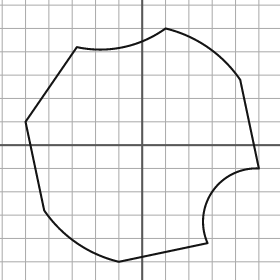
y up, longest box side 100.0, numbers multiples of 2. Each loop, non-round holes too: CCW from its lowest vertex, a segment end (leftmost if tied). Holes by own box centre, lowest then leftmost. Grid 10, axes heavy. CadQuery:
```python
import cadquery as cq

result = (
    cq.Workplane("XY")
    .moveTo(-10.0, -50.0)
    .lineTo(28.0, -42.0)
    .threePointArc((30.0, -20.0), (50.0, -10.0))
    .lineTo(42.0, 28.0)
    .threePointArc((28.0, 42.0), (10.0, 50.0))
    .threePointArc((-8.0, 42.0), (-28.0, 42.0))
    .lineTo(-50.0, 10.0)
    .lineTo(-42.0, -28.0)
    .threePointArc((-28.0, -42.0), (-10.0, -50.0))
    .close()
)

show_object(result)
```